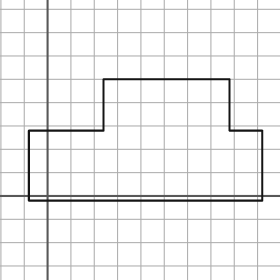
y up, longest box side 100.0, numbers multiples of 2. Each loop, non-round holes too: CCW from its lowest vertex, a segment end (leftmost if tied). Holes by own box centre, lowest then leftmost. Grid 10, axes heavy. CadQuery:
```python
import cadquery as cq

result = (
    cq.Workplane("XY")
    .moveTo(-8.0, -2.0)
    .lineTo(92.0, -2.0)
    .lineTo(92.0, 28.0)
    .lineTo(78.0, 28.0)
    .lineTo(78.0, 50.0)
    .lineTo(24.0, 50.0)
    .lineTo(24.0, 28.0)
    .lineTo(-8.0, 28.0)
    .close()
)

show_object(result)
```